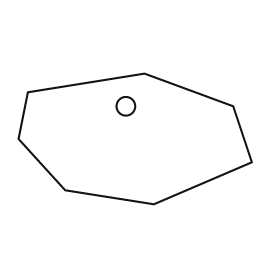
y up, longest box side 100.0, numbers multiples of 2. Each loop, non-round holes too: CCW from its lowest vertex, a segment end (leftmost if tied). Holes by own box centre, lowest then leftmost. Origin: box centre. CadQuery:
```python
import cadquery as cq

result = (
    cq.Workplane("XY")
    .moveTo(8.0, -28.0)
    .lineTo(50.0, -10.0)
    .lineTo(42.0, 14.0)
    .lineTo(4.0, 28.0)
    .lineTo(-46.0, 20.0)
    .lineTo(-50.0, 0.0)
    .lineTo(-30.0, -22.0)
    .close()
    .moveTo(-4.0, 14.0)
    .circle(4.0)
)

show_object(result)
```